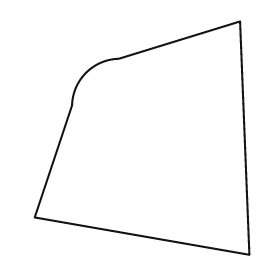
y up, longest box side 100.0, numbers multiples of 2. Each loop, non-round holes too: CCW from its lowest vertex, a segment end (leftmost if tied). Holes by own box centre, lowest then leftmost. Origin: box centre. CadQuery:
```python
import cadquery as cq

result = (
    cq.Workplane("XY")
    .moveTo(46.0, -50.0)
    .lineTo(42.0, 50.0)
    .lineTo(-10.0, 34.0)
    .threePointArc((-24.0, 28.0), (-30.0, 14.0))
    .lineTo(-46.0, -34.0)
    .close()
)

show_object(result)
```